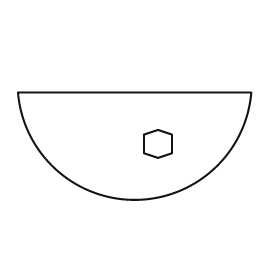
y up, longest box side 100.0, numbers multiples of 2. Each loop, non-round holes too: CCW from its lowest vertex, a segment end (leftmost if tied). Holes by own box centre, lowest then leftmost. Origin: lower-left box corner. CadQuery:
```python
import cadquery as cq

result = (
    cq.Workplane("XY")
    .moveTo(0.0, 46.0)
    .threePointArc((50.0, 0.0), (100.0, 46.0))
    .close()
    .moveTo(60.0, 18.0)
    .lineTo(66.0, 20.0)
    .lineTo(66.0, 28.0)
    .lineTo(60.0, 30.0)
    .lineTo(54.0, 28.0)
    .lineTo(54.0, 20.0)
    .close()
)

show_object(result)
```